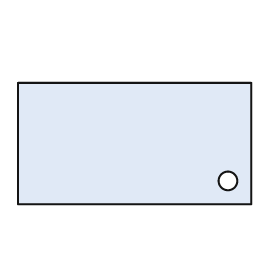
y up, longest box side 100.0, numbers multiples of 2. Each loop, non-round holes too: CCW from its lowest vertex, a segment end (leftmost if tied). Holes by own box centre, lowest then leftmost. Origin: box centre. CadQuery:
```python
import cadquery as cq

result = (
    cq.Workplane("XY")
    .moveTo(-50.0, -26.0)
    .lineTo(50.0, -26.0)
    .lineTo(50.0, 26.0)
    .lineTo(-50.0, 26.0)
    .close()
    .moveTo(40.0, -16.0)
    .circle(4.0)
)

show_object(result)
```